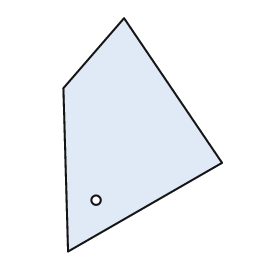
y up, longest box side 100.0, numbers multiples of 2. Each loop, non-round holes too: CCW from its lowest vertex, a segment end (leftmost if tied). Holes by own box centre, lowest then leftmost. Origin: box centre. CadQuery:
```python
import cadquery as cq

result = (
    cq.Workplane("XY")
    .moveTo(-32.0, -50.0)
    .lineTo(34.0, -12.0)
    .lineTo(-8.0, 50.0)
    .lineTo(-34.0, 20.0)
    .close()
    .moveTo(-20.0, -28.0)
    .circle(2.0)
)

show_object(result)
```